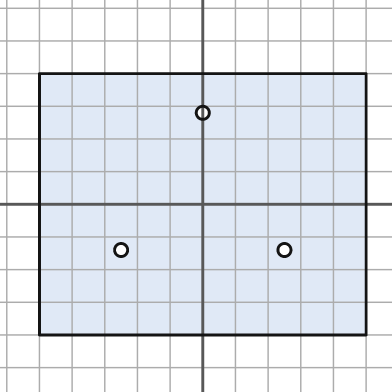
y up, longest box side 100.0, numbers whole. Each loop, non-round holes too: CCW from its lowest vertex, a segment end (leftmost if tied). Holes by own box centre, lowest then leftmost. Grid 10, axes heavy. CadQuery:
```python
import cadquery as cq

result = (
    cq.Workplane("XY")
    .moveTo(-50.0, -40.0)
    .lineTo(50.0, -40.0)
    .lineTo(50.0, 40.0)
    .lineTo(-50.0, 40.0)
    .close()
    .moveTo(-25.0, -14.0)
    .circle(2.0)
    .moveTo(25.0, -14.0)
    .circle(2.0)
    .moveTo(0.0, 28.0)
    .circle(2.0)
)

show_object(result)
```